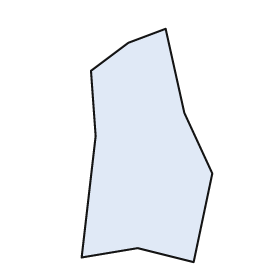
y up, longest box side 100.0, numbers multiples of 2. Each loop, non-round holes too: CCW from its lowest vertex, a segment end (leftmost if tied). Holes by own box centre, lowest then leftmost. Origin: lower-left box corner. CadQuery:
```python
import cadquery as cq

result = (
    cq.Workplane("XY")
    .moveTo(48.0, 0.0)
    .lineTo(56.0, 38.0)
    .lineTo(44.0, 64.0)
    .lineTo(36.0, 100.0)
    .lineTo(20.0, 94.0)
    .lineTo(4.0, 82.0)
    .lineTo(6.0, 54.0)
    .lineTo(0.0, 2.0)
    .lineTo(24.0, 6.0)
    .close()
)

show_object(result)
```